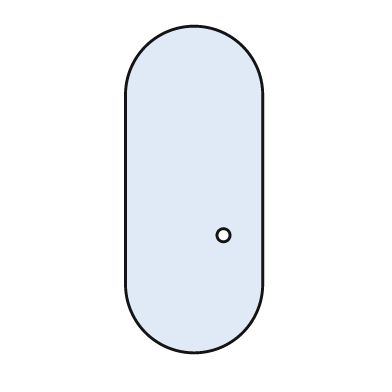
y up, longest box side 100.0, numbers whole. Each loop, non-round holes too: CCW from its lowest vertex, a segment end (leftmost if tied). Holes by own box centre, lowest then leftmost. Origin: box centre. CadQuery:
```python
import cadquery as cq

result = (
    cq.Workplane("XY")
    .moveTo(-21.0, -29.0)
    .threePointArc((0.0, -50.0), (21.0, -29.0))
    .lineTo(21.0, 29.0)
    .threePointArc((0.0, 50.0), (-21.0, 29.0))
    .close()
    .moveTo(9.0, -14.0)
    .circle(2.0)
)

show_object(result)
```